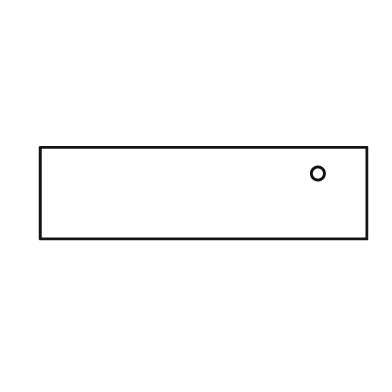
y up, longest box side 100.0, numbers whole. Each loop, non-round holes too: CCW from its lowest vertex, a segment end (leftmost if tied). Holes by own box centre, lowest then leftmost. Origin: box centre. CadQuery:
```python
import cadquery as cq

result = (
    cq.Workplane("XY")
    .moveTo(-50.0, -14.0)
    .lineTo(50.0, -14.0)
    .lineTo(50.0, 14.0)
    .lineTo(-50.0, 14.0)
    .close()
    .moveTo(35.0, 6.0)
    .circle(2.0)
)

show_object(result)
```